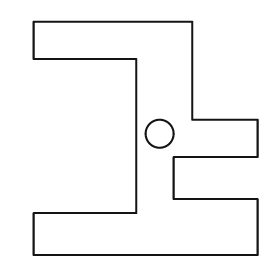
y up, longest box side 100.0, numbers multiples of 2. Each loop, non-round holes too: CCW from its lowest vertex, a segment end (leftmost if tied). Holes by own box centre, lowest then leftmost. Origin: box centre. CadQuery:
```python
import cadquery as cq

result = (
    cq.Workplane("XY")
    .moveTo(-48.0, -50.0)
    .lineTo(48.0, -50.0)
    .lineTo(48.0, -26.0)
    .lineTo(12.0, -26.0)
    .lineTo(12.0, -8.0)
    .lineTo(48.0, -8.0)
    .lineTo(48.0, 8.0)
    .lineTo(20.0, 8.0)
    .lineTo(20.0, 50.0)
    .lineTo(-48.0, 50.0)
    .lineTo(-48.0, 34.0)
    .lineTo(-4.0, 34.0)
    .lineTo(-4.0, -32.0)
    .lineTo(-48.0, -32.0)
    .close()
    .moveTo(6.0, 2.0)
    .circle(6.0)
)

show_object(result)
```